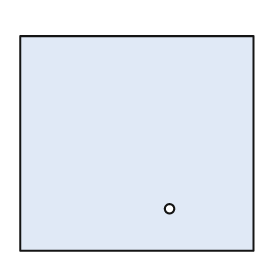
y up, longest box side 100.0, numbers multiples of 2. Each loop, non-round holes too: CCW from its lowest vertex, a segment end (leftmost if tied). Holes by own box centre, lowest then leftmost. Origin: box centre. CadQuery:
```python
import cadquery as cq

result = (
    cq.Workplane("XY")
    .moveTo(-50.0, -46.0)
    .lineTo(50.0, -46.0)
    .lineTo(50.0, 46.0)
    .lineTo(-50.0, 46.0)
    .close()
    .moveTo(14.0, -28.0)
    .circle(2.0)
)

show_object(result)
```